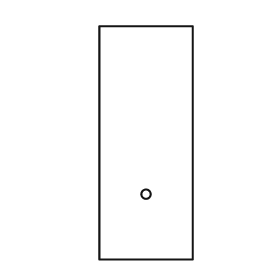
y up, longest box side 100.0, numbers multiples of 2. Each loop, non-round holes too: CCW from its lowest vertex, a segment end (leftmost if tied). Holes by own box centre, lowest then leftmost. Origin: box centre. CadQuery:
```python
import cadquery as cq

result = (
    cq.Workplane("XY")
    .moveTo(-20.0, -50.0)
    .lineTo(20.0, -50.0)
    .lineTo(20.0, 50.0)
    .lineTo(-20.0, 50.0)
    .close()
    .moveTo(0.0, -22.0)
    .circle(2.0)
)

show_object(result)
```